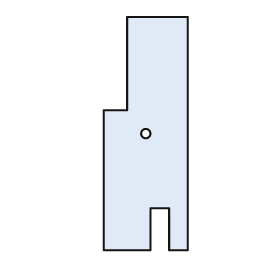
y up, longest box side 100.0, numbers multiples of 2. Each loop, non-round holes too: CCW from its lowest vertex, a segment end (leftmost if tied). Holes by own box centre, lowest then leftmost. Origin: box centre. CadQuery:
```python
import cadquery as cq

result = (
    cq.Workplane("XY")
    .moveTo(-18.0, -50.0)
    .lineTo(2.0, -50.0)
    .lineTo(2.0, -32.0)
    .lineTo(10.0, -32.0)
    .lineTo(10.0, -50.0)
    .lineTo(18.0, -50.0)
    .lineTo(18.0, 50.0)
    .lineTo(-8.0, 50.0)
    .lineTo(-8.0, 10.0)
    .lineTo(-18.0, 10.0)
    .close()
    .moveTo(0.0, 0.0)
    .circle(2.0)
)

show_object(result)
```